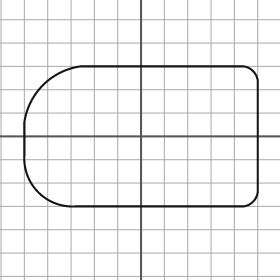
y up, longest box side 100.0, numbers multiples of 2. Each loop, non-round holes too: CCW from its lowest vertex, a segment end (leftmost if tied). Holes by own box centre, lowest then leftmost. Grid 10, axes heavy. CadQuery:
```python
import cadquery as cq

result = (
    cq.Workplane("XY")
    .moveTo(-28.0, -30.0)
    .lineTo(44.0, -30.0)
    .threePointArc((48.0, -28.0), (50.0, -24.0))
    .lineTo(50.0, 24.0)
    .threePointArc((48.0, 28.0), (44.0, 30.0))
    .lineTo(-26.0, 30.0)
    .threePointArc((-42.0, 22.0), (-50.0, 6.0))
    .lineTo(-50.0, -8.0)
    .threePointArc((-44.0, -24.0), (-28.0, -30.0))
    .close()
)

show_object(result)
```